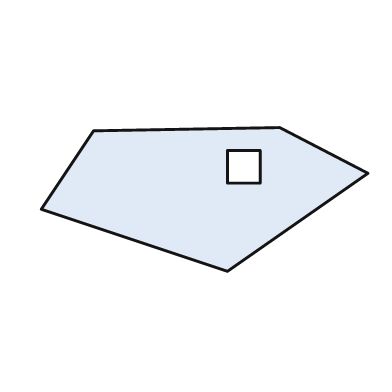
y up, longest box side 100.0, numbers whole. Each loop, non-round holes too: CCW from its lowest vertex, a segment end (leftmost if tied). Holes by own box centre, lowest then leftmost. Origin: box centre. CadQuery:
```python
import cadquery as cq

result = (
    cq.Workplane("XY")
    .moveTo(7.0, -22.0)
    .lineTo(50.0, 8.0)
    .lineTo(23.0, 22.0)
    .lineTo(-34.0, 21.0)
    .lineTo(-50.0, -3.0)
    .close()
    .moveTo(7.0, 5.0)
    .lineTo(17.0, 5.0)
    .lineTo(17.0, 15.0)
    .lineTo(7.0, 15.0)
    .close()
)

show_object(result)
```